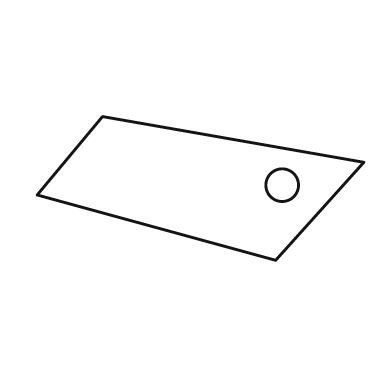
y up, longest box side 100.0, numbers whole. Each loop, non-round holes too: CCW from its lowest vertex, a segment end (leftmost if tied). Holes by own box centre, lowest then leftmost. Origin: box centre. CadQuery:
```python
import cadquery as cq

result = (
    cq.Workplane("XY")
    .moveTo(23.0, -22.0)
    .lineTo(50.0, 8.0)
    .lineTo(-30.0, 22.0)
    .lineTo(-50.0, -2.0)
    .close()
    .moveTo(25.0, 1.0)
    .circle(5.0)
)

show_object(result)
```